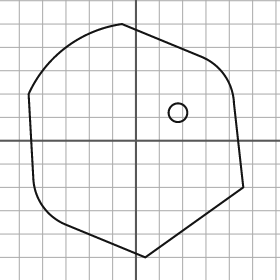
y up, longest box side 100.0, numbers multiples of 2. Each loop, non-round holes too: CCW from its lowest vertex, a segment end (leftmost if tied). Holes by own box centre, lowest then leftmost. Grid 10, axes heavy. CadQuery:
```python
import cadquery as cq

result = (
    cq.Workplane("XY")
    .moveTo(4.0, -50.0)
    .lineTo(46.0, -20.0)
    .lineTo(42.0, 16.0)
    .threePointArc((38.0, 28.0), (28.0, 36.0))
    .lineTo(-6.0, 50.0)
    .threePointArc((-30.0, 40.0), (-46.0, 20.0))
    .lineTo(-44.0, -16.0)
    .threePointArc((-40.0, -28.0), (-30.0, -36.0))
    .close()
    .moveTo(18.0, 12.0)
    .circle(4.0)
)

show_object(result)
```